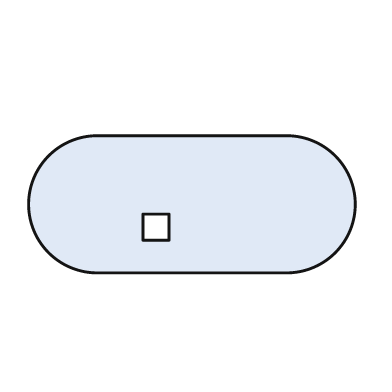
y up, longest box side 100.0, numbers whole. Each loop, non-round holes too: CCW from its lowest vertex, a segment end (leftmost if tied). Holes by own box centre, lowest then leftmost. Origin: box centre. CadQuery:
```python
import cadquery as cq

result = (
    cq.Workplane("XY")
    .moveTo(-29.0, -21.0)
    .lineTo(29.0, -21.0)
    .threePointArc((50.0, 0.0), (29.0, 21.0))
    .lineTo(-29.0, 21.0)
    .threePointArc((-50.0, 0.0), (-29.0, -21.0))
    .close()
    .moveTo(-15.0, -11.0)
    .lineTo(-7.0, -11.0)
    .lineTo(-7.0, -3.0)
    .lineTo(-15.0, -3.0)
    .close()
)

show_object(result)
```